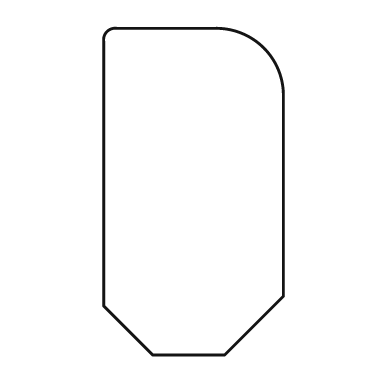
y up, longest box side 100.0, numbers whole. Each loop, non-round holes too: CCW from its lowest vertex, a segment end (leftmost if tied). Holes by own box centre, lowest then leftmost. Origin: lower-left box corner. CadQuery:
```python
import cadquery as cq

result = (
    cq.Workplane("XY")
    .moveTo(15.0, 0.0)
    .lineTo(37.0, 0.0)
    .lineTo(55.0, 18.0)
    .lineTo(55.0, 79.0)
    .threePointArc((49.0, 94.0), (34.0, 100.0))
    .lineTo(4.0, 100.0)
    .threePointArc((1.0, 99.0), (0.0, 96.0))
    .lineTo(0.0, 15.0)
    .close()
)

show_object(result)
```